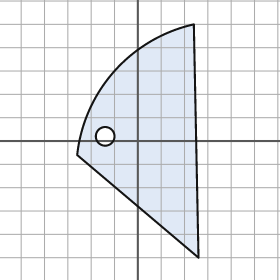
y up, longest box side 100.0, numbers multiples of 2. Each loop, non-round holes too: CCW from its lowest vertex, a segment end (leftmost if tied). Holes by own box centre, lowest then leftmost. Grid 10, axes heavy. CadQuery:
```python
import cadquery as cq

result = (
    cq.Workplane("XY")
    .moveTo(26.0, -50.0)
    .lineTo(24.0, 50.0)
    .threePointArc((-10.0, 30.0), (-26.0, -6.0))
    .close()
    .moveTo(-14.0, 2.0)
    .circle(4.0)
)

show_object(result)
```